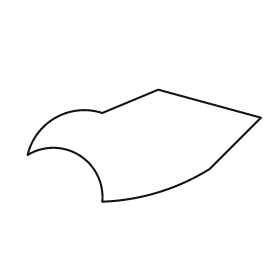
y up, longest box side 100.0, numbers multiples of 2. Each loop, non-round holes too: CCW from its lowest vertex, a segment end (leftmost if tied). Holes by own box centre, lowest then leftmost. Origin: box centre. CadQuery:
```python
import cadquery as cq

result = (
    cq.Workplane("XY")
    .moveTo(-18.0, -24.0)
    .threePointArc((6.0, -20.0), (28.0, -10.0))
    .lineTo(50.0, 12.0)
    .lineTo(6.0, 24.0)
    .lineTo(-18.0, 14.0)
    .threePointArc((-38.0, 12.0), (-50.0, -4.0))
    .threePointArc((-28.0, -4.0), (-18.0, -24.0))
    .close()
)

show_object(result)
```